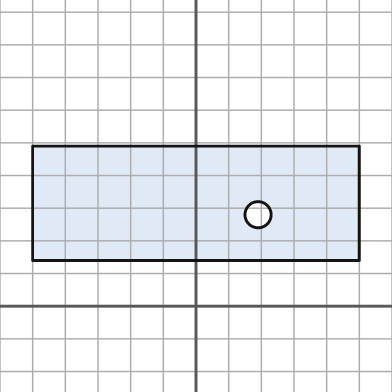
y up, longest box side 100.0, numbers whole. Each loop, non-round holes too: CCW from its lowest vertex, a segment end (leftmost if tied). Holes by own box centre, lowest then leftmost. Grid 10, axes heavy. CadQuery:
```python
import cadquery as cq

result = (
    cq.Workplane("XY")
    .moveTo(-50.0, 14.0)
    .lineTo(50.0, 14.0)
    .lineTo(50.0, 49.0)
    .lineTo(-50.0, 49.0)
    .close()
    .moveTo(19.0, 28.0)
    .circle(4.0)
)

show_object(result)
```